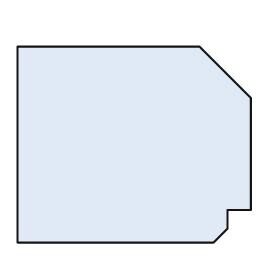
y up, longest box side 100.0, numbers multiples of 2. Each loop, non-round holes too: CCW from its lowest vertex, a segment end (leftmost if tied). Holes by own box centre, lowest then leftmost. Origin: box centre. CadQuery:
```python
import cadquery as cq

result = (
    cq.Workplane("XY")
    .moveTo(-50.0, -42.0)
    .lineTo(34.0, -42.0)
    .lineTo(40.0, -36.0)
    .lineTo(40.0, -28.0)
    .lineTo(50.0, -28.0)
    .lineTo(50.0, 20.0)
    .lineTo(28.0, 42.0)
    .lineTo(-50.0, 42.0)
    .close()
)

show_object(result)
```